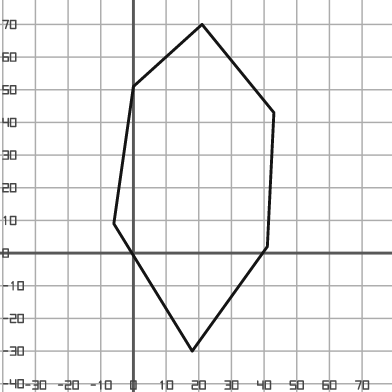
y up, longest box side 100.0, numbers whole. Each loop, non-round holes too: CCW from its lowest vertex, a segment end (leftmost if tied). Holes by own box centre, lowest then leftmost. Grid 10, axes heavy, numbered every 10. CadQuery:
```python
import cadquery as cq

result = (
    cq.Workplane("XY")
    .moveTo(18.0, -30.0)
    .lineTo(41.0, 2.0)
    .lineTo(43.0, 43.0)
    .lineTo(21.0, 70.0)
    .lineTo(0.0, 51.0)
    .lineTo(-6.0, 9.0)
    .close()
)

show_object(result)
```